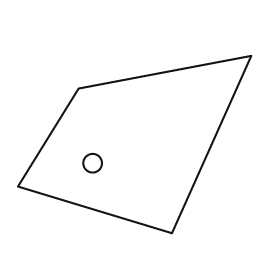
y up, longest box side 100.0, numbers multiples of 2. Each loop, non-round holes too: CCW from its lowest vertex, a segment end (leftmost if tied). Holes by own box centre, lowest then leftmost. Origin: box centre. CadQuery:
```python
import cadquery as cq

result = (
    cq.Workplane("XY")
    .moveTo(16.0, -38.0)
    .lineTo(50.0, 38.0)
    .lineTo(-24.0, 24.0)
    .lineTo(-50.0, -18.0)
    .close()
    .moveTo(-18.0, -8.0)
    .circle(4.0)
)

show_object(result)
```